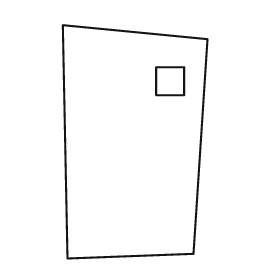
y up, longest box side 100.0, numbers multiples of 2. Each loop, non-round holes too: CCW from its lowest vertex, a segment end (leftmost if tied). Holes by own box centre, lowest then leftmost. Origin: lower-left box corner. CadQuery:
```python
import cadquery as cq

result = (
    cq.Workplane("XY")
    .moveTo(2.0, 0.0)
    .lineTo(56.0, 2.0)
    .lineTo(62.0, 94.0)
    .lineTo(0.0, 100.0)
    .close()
    .moveTo(40.0, 70.0)
    .lineTo(52.0, 70.0)
    .lineTo(52.0, 82.0)
    .lineTo(40.0, 82.0)
    .close()
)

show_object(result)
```